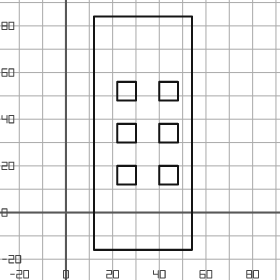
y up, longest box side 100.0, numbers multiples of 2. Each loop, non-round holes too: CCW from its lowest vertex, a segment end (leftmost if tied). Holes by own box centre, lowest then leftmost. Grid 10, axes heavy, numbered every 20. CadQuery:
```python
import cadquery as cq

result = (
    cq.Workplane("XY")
    .moveTo(12.0, -16.0)
    .lineTo(54.0, -16.0)
    .lineTo(54.0, 84.0)
    .lineTo(12.0, 84.0)
    .close()
    .moveTo(22.0, 12.0)
    .lineTo(30.0, 12.0)
    .lineTo(30.0, 20.0)
    .lineTo(22.0, 20.0)
    .close()
    .moveTo(40.0, 12.0)
    .lineTo(48.0, 12.0)
    .lineTo(48.0, 20.0)
    .lineTo(40.0, 20.0)
    .close()
    .moveTo(22.0, 30.0)
    .lineTo(30.0, 30.0)
    .lineTo(30.0, 38.0)
    .lineTo(22.0, 38.0)
    .close()
    .moveTo(40.0, 30.0)
    .lineTo(48.0, 30.0)
    .lineTo(48.0, 38.0)
    .lineTo(40.0, 38.0)
    .close()
    .moveTo(22.0, 48.0)
    .lineTo(30.0, 48.0)
    .lineTo(30.0, 56.0)
    .lineTo(22.0, 56.0)
    .close()
    .moveTo(40.0, 48.0)
    .lineTo(48.0, 48.0)
    .lineTo(48.0, 56.0)
    .lineTo(40.0, 56.0)
    .close()
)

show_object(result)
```